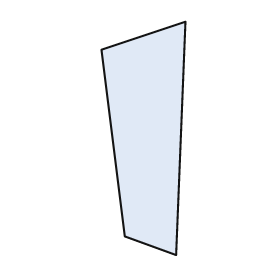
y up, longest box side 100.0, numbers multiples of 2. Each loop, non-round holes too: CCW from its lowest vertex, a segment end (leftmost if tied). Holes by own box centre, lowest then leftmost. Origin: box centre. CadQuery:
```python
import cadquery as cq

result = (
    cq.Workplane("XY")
    .moveTo(14.0, -50.0)
    .lineTo(18.0, 50.0)
    .lineTo(-18.0, 38.0)
    .lineTo(-8.0, -42.0)
    .close()
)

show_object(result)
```